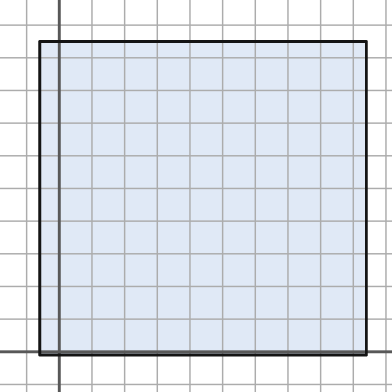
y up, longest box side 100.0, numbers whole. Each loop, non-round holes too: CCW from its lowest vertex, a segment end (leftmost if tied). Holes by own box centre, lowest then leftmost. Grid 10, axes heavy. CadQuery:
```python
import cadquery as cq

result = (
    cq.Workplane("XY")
    .moveTo(-6.0, -1.0)
    .lineTo(94.0, -1.0)
    .lineTo(94.0, 95.0)
    .lineTo(-6.0, 95.0)
    .close()
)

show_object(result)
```